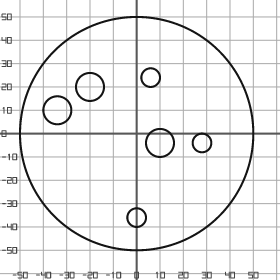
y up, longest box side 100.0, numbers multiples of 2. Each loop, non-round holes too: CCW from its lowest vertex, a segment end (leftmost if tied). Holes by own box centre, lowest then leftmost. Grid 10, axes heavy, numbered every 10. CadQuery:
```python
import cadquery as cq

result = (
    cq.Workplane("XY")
    .moveTo(0.0, 0.0)
    .circle(50.0)
    .moveTo(0.0, -36.0)
    .circle(4.0)
    .moveTo(10.0, -4.0)
    .circle(6.0)
    .moveTo(28.0, -4.0)
    .circle(4.0)
    .moveTo(-34.0, 10.0)
    .circle(6.0)
    .moveTo(-20.0, 20.0)
    .circle(6.0)
    .moveTo(6.0, 24.0)
    .circle(4.0)
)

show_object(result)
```